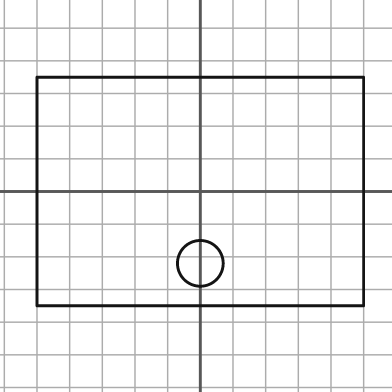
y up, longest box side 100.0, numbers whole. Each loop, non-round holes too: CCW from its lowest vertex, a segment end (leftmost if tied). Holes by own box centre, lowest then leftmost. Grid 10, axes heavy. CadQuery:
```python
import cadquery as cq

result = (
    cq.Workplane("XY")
    .moveTo(-50.0, -35.0)
    .lineTo(50.0, -35.0)
    .lineTo(50.0, 35.0)
    .lineTo(-50.0, 35.0)
    .close()
    .moveTo(0.0, -22.0)
    .circle(7.0)
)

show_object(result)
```